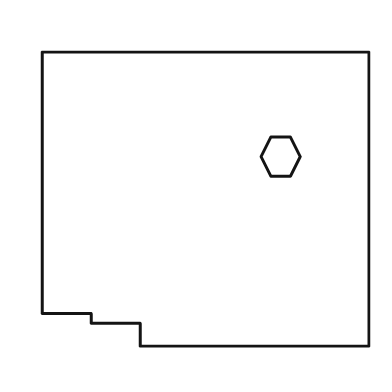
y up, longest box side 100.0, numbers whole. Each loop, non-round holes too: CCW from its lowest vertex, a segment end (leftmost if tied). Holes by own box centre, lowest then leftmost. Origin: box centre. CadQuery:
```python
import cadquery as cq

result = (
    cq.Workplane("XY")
    .moveTo(-20.0, -45.0)
    .lineTo(50.0, -45.0)
    .lineTo(50.0, 45.0)
    .lineTo(-50.0, 45.0)
    .lineTo(-50.0, -35.0)
    .lineTo(-35.0, -35.0)
    .lineTo(-35.0, -38.0)
    .lineTo(-20.0, -38.0)
    .close()
    .moveTo(20.0, 7.0)
    .lineTo(26.0, 7.0)
    .lineTo(29.0, 13.0)
    .lineTo(26.0, 19.0)
    .lineTo(20.0, 19.0)
    .lineTo(17.0, 13.0)
    .close()
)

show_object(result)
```